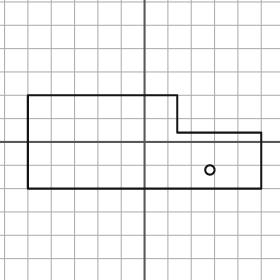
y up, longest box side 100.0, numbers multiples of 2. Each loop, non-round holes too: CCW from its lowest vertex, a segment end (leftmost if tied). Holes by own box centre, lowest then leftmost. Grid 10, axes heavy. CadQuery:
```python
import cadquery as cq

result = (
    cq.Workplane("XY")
    .moveTo(-50.0, -20.0)
    .lineTo(50.0, -20.0)
    .lineTo(50.0, 4.0)
    .lineTo(14.0, 4.0)
    .lineTo(14.0, 20.0)
    .lineTo(-50.0, 20.0)
    .close()
    .moveTo(28.0, -12.0)
    .circle(2.0)
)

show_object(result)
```